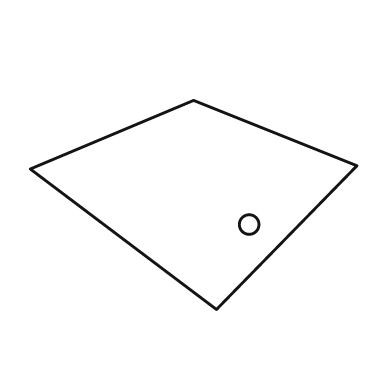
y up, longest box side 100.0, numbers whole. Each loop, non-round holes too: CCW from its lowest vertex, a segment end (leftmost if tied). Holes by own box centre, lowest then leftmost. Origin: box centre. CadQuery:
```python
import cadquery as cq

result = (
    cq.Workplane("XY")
    .moveTo(7.0, -32.0)
    .lineTo(50.0, 12.0)
    .lineTo(0.0, 32.0)
    .lineTo(-50.0, 11.0)
    .close()
    .moveTo(17.0, -6.0)
    .circle(3.0)
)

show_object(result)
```